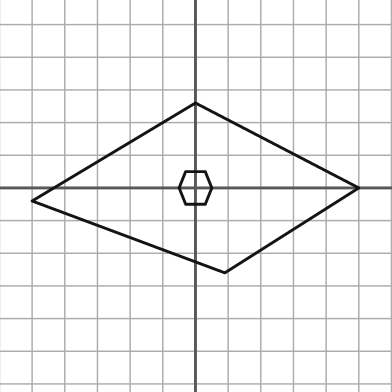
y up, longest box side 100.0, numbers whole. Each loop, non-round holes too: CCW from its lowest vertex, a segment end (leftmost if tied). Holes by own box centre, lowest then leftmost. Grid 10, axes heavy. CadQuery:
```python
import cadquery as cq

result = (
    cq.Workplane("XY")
    .moveTo(9.0, -26.0)
    .lineTo(50.0, 0.0)
    .lineTo(0.0, 26.0)
    .lineTo(-50.0, -4.0)
    .close()
    .moveTo(-3.0, -5.0)
    .lineTo(3.0, -5.0)
    .lineTo(5.0, 0.0)
    .lineTo(3.0, 5.0)
    .lineTo(-3.0, 5.0)
    .lineTo(-5.0, 0.0)
    .close()
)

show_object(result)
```